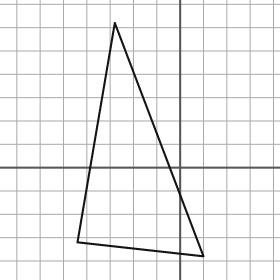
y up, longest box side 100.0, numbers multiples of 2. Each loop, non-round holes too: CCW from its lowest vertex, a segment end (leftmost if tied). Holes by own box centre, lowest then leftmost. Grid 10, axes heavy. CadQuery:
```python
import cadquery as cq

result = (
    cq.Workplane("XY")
    .moveTo(10.0, -38.0)
    .lineTo(-28.0, 62.0)
    .lineTo(-44.0, -32.0)
    .close()
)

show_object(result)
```